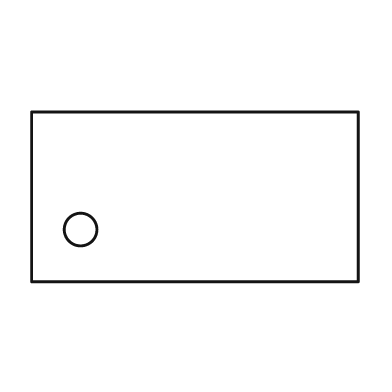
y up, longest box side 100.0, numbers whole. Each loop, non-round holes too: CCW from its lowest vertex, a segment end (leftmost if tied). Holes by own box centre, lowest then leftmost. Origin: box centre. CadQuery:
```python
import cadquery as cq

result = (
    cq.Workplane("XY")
    .moveTo(-50.0, -26.0)
    .lineTo(50.0, -26.0)
    .lineTo(50.0, 26.0)
    .lineTo(-50.0, 26.0)
    .close()
    .moveTo(-35.0, -10.0)
    .circle(5.0)
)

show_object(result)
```